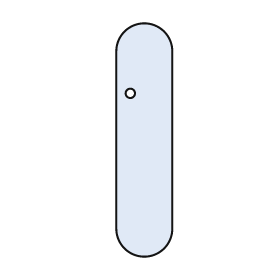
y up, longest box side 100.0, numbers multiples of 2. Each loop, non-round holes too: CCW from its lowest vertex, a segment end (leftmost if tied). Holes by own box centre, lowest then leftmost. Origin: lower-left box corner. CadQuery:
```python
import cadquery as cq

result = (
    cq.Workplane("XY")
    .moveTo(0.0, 12.0)
    .threePointArc((12.0, 0.0), (24.0, 12.0))
    .lineTo(24.0, 88.0)
    .threePointArc((12.0, 100.0), (0.0, 88.0))
    .close()
    .moveTo(6.0, 70.0)
    .circle(2.0)
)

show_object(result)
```